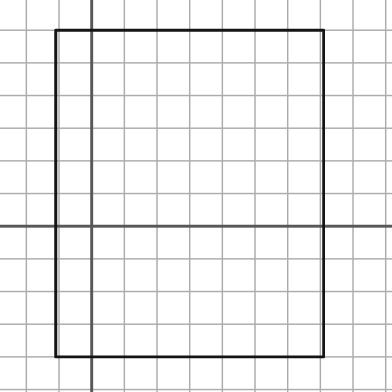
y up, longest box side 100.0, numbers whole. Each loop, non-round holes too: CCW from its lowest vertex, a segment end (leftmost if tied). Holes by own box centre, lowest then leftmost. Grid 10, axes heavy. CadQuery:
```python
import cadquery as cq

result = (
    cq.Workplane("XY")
    .moveTo(-11.0, -40.0)
    .lineTo(71.0, -40.0)
    .lineTo(71.0, 60.0)
    .lineTo(-11.0, 60.0)
    .close()
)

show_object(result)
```